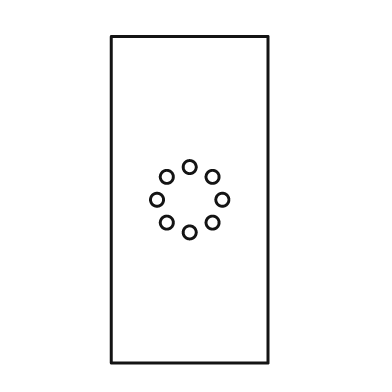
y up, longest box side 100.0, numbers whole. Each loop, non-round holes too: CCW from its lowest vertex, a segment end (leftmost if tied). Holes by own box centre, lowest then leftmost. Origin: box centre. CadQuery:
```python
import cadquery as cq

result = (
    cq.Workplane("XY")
    .moveTo(-24.0, -50.0)
    .lineTo(24.0, -50.0)
    .lineTo(24.0, 50.0)
    .lineTo(-24.0, 50.0)
    .close()
    .moveTo(0.0, -10.0)
    .circle(2.0)
    .moveTo(-7.0, -7.0)
    .circle(2.0)
    .moveTo(7.0, -7.0)
    .circle(2.0)
    .moveTo(-10.0, 0.0)
    .circle(2.0)
    .moveTo(10.0, 0.0)
    .circle(2.0)
    .moveTo(-7.0, 7.0)
    .circle(2.0)
    .moveTo(7.0, 7.0)
    .circle(2.0)
    .moveTo(0.0, 10.0)
    .circle(2.0)
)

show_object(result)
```